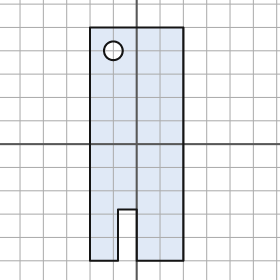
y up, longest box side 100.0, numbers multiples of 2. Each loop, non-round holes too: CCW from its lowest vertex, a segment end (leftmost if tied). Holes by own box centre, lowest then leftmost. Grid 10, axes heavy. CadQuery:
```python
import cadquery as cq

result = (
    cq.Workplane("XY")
    .moveTo(-20.0, -50.0)
    .lineTo(-8.0, -50.0)
    .lineTo(-8.0, -28.0)
    .lineTo(0.0, -28.0)
    .lineTo(0.0, -50.0)
    .lineTo(20.0, -50.0)
    .lineTo(20.0, 50.0)
    .lineTo(-20.0, 50.0)
    .close()
    .moveTo(-10.0, 40.0)
    .circle(4.0)
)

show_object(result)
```